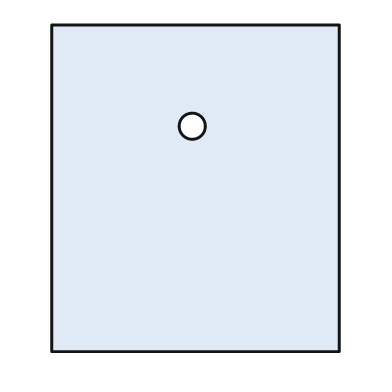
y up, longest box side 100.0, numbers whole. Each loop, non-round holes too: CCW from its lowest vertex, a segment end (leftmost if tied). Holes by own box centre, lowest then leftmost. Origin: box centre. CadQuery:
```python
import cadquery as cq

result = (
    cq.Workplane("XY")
    .moveTo(-44.0, -50.0)
    .lineTo(44.0, -50.0)
    .lineTo(44.0, 50.0)
    .lineTo(-44.0, 50.0)
    .close()
    .moveTo(-1.0, 19.0)
    .circle(4.0)
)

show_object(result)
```